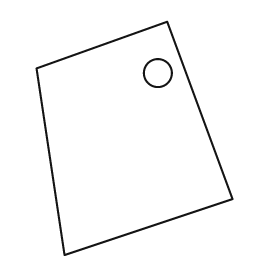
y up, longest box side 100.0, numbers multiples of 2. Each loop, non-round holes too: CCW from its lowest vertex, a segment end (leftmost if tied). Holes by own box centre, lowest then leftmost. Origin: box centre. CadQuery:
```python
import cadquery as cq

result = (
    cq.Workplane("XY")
    .moveTo(-30.0, -50.0)
    .lineTo(42.0, -26.0)
    .lineTo(14.0, 50.0)
    .lineTo(-42.0, 30.0)
    .close()
    .moveTo(10.0, 28.0)
    .circle(6.0)
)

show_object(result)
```